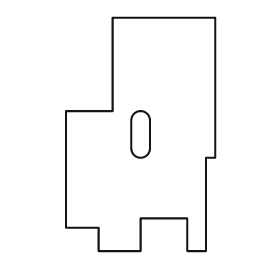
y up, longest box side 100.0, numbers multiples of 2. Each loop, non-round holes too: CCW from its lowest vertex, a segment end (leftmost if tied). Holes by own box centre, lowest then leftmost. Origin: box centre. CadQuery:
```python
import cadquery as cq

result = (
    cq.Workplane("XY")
    .moveTo(-18.0, -50.0)
    .lineTo(0.0, -50.0)
    .lineTo(0.0, -36.0)
    .lineTo(20.0, -36.0)
    .lineTo(20.0, -50.0)
    .lineTo(28.0, -50.0)
    .lineTo(28.0, -10.0)
    .lineTo(32.0, -10.0)
    .lineTo(32.0, 50.0)
    .lineTo(-12.0, 50.0)
    .lineTo(-12.0, 10.0)
    .lineTo(-32.0, 10.0)
    .lineTo(-32.0, -40.0)
    .lineTo(-18.0, -40.0)
    .close()
    .moveTo(-4.0, -6.0)
    .threePointArc((0.0, -10.0), (4.0, -6.0))
    .lineTo(4.0, 6.0)
    .threePointArc((0.0, 10.0), (-4.0, 6.0))
    .close()
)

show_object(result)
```